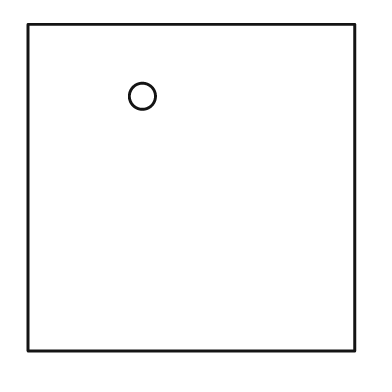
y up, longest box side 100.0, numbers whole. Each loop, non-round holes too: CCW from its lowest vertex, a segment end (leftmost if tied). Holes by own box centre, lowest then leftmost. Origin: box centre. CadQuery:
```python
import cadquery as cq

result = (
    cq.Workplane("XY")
    .moveTo(-50.0, -50.0)
    .lineTo(50.0, -50.0)
    .lineTo(50.0, 50.0)
    .lineTo(-50.0, 50.0)
    .close()
    .moveTo(-15.0, 28.0)
    .circle(4.0)
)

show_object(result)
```